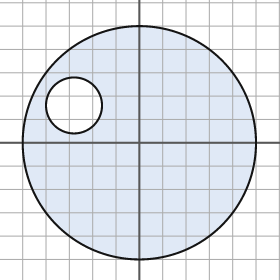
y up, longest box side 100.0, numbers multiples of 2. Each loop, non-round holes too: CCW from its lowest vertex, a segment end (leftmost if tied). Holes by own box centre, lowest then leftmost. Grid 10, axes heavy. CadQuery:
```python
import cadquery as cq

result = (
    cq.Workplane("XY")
    .moveTo(0.0, 0.0)
    .circle(50.0)
    .moveTo(-28.0, 16.0)
    .circle(12.0)
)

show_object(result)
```